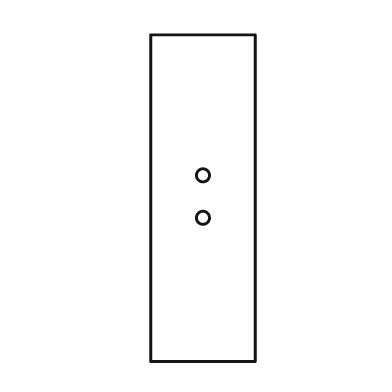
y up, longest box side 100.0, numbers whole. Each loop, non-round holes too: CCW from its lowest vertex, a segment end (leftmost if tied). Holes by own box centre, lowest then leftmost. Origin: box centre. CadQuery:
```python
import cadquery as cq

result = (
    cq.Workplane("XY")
    .moveTo(-16.0, -50.0)
    .lineTo(16.0, -50.0)
    .lineTo(16.0, 50.0)
    .lineTo(-16.0, 50.0)
    .close()
    .moveTo(0.0, -6.0)
    .circle(2.0)
    .moveTo(0.0, 7.0)
    .circle(2.0)
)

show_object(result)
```